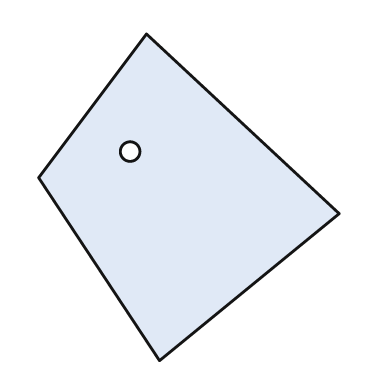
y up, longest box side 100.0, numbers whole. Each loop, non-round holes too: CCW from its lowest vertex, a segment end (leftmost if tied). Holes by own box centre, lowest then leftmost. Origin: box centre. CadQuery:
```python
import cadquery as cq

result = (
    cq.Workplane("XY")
    .moveTo(-9.0, -50.0)
    .lineTo(46.0, -5.0)
    .lineTo(-13.0, 50.0)
    .lineTo(-46.0, 6.0)
    .close()
    .moveTo(-18.0, 14.0)
    .circle(3.0)
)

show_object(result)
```